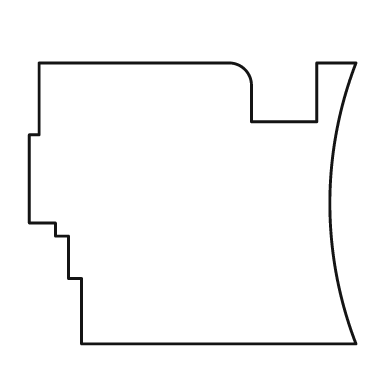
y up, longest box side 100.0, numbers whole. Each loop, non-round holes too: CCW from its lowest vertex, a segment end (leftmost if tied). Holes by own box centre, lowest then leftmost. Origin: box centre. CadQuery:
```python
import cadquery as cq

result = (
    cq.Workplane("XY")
    .moveTo(-34.0, -43.0)
    .lineTo(50.0, -43.0)
    .threePointArc((42.0, 0.0), (50.0, 43.0))
    .lineTo(38.0, 43.0)
    .lineTo(38.0, 25.0)
    .lineTo(18.0, 25.0)
    .lineTo(18.0, 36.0)
    .threePointArc((16.0, 41.0), (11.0, 43.0))
    .lineTo(-47.0, 43.0)
    .lineTo(-47.0, 21.0)
    .lineTo(-50.0, 21.0)
    .lineTo(-50.0, -6.0)
    .lineTo(-42.0, -6.0)
    .lineTo(-42.0, -10.0)
    .lineTo(-38.0, -10.0)
    .lineTo(-38.0, -23.0)
    .lineTo(-34.0, -23.0)
    .close()
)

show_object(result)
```